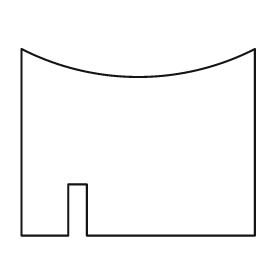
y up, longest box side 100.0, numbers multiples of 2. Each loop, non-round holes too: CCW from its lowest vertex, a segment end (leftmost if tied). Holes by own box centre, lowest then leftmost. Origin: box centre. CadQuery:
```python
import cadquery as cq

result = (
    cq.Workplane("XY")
    .moveTo(-50.0, -40.0)
    .lineTo(-30.0, -40.0)
    .lineTo(-30.0, -18.0)
    .lineTo(-22.0, -18.0)
    .lineTo(-22.0, -40.0)
    .lineTo(50.0, -40.0)
    .lineTo(50.0, 40.0)
    .threePointArc((0.0, 28.0), (-50.0, 40.0))
    .close()
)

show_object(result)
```